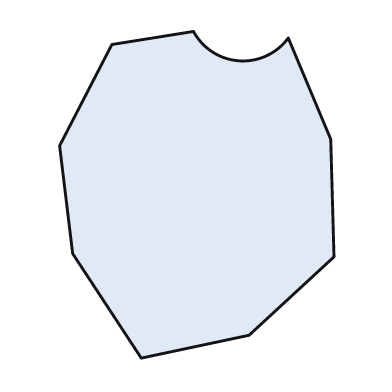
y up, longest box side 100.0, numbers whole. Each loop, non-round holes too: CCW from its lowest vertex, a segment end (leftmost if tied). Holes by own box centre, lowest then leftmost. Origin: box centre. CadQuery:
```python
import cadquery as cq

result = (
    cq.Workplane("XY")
    .moveTo(-17.0, -50.0)
    .lineTo(16.0, -43.0)
    .lineTo(42.0, -19.0)
    .lineTo(41.0, 17.0)
    .lineTo(28.0, 48.0)
    .threePointArc((13.0, 41.0), (-1.0, 50.0))
    .lineTo(-26.0, 46.0)
    .lineTo(-42.0, 15.0)
    .lineTo(-38.0, -18.0)
    .close()
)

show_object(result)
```